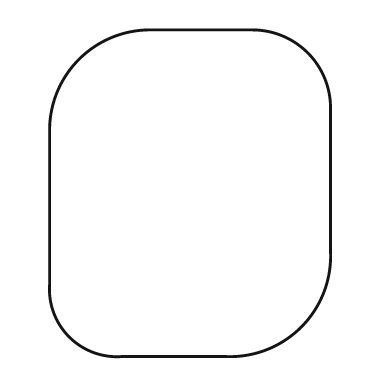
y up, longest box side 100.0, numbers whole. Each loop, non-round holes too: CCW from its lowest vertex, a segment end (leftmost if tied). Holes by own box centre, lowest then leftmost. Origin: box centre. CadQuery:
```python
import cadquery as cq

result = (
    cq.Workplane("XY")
    .moveTo(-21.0, -50.0)
    .lineTo(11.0, -50.0)
    .threePointArc((34.0, -41.0), (43.0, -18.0))
    .lineTo(43.0, 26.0)
    .threePointArc((36.0, 43.0), (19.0, 50.0))
    .lineTo(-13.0, 50.0)
    .threePointArc((-34.0, 41.0), (-43.0, 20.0))
    .lineTo(-43.0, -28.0)
    .threePointArc((-37.0, -44.0), (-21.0, -50.0))
    .close()
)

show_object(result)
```